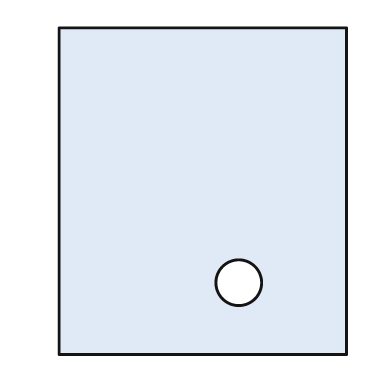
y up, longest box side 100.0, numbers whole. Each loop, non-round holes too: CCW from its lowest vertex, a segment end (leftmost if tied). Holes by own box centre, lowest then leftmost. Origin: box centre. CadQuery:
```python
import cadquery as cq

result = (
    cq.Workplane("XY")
    .moveTo(-44.0, -50.0)
    .lineTo(44.0, -50.0)
    .lineTo(44.0, 50.0)
    .lineTo(-44.0, 50.0)
    .close()
    .moveTo(11.0, -28.0)
    .circle(7.0)
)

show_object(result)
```